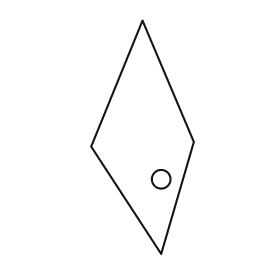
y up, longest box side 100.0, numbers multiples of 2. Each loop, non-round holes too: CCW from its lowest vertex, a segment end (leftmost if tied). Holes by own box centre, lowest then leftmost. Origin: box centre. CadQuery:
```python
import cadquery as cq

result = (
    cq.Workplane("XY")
    .moveTo(8.0, -50.0)
    .lineTo(22.0, -2.0)
    .lineTo(0.0, 50.0)
    .lineTo(-22.0, -4.0)
    .close()
    .moveTo(8.0, -18.0)
    .circle(4.0)
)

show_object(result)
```